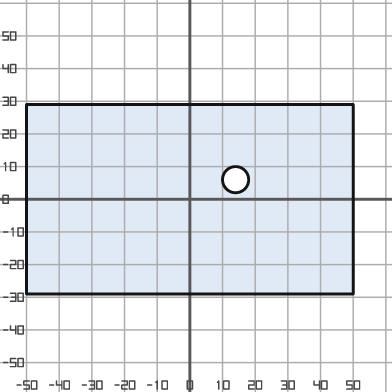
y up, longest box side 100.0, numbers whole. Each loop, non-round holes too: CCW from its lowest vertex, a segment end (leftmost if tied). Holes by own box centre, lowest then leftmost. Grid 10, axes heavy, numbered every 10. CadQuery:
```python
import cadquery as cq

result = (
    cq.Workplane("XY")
    .moveTo(-50.0, -29.0)
    .lineTo(50.0, -29.0)
    .lineTo(50.0, 29.0)
    .lineTo(-50.0, 29.0)
    .close()
    .moveTo(14.0, 6.0)
    .circle(4.0)
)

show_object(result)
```